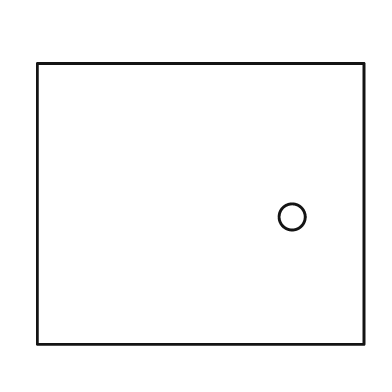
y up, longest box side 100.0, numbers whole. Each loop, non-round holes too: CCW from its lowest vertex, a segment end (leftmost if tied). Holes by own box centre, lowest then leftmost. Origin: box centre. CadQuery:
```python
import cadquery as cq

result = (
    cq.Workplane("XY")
    .moveTo(-50.0, -43.0)
    .lineTo(50.0, -43.0)
    .lineTo(50.0, 43.0)
    .lineTo(-50.0, 43.0)
    .close()
    .moveTo(28.0, -4.0)
    .circle(4.0)
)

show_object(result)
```